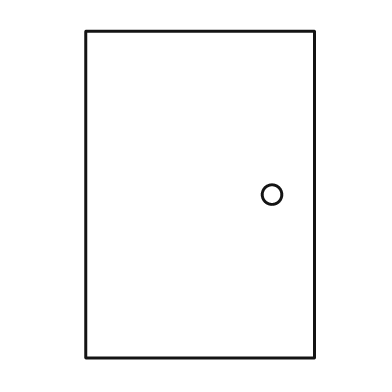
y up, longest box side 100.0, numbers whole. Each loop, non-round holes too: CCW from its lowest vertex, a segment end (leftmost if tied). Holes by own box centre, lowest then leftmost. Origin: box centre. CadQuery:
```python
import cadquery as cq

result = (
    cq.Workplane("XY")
    .moveTo(-35.0, -50.0)
    .lineTo(35.0, -50.0)
    .lineTo(35.0, 50.0)
    .lineTo(-35.0, 50.0)
    .close()
    .moveTo(22.0, 0.0)
    .circle(3.0)
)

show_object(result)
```